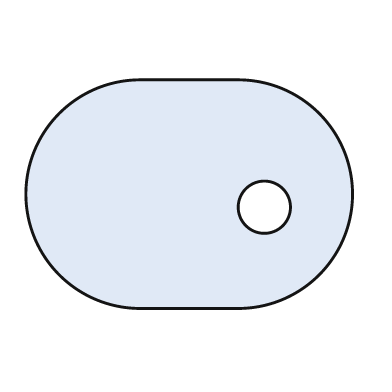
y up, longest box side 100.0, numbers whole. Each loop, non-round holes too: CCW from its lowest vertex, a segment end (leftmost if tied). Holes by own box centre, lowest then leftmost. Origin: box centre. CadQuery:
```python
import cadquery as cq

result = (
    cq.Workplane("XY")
    .moveTo(-15.0, -35.0)
    .lineTo(15.0, -35.0)
    .threePointArc((50.0, 0.0), (15.0, 35.0))
    .lineTo(-15.0, 35.0)
    .threePointArc((-50.0, 0.0), (-15.0, -35.0))
    .close()
    .moveTo(23.0, -4.0)
    .circle(8.0)
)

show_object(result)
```